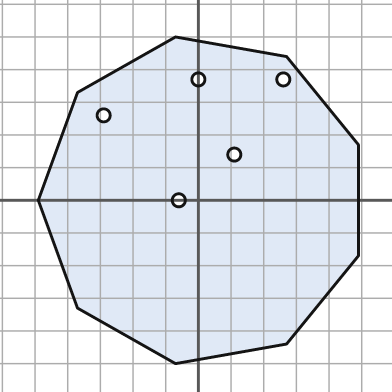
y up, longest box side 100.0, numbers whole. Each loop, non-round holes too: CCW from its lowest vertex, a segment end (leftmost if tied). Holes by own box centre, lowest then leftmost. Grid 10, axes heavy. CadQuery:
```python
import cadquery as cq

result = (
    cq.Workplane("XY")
    .moveTo(-7.0, -50.0)
    .lineTo(27.0, -44.0)
    .lineTo(49.0, -17.0)
    .lineTo(49.0, 17.0)
    .lineTo(27.0, 44.0)
    .lineTo(-7.0, 50.0)
    .lineTo(-37.0, 33.0)
    .lineTo(-49.0, 0.0)
    .lineTo(-37.0, -33.0)
    .close()
    .moveTo(-6.0, 0.0)
    .circle(2.0)
    .moveTo(11.0, 14.0)
    .circle(2.0)
    .moveTo(-29.0, 26.0)
    .circle(2.0)
    .moveTo(0.0, 37.0)
    .circle(2.0)
    .moveTo(26.0, 37.0)
    .circle(2.0)
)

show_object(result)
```